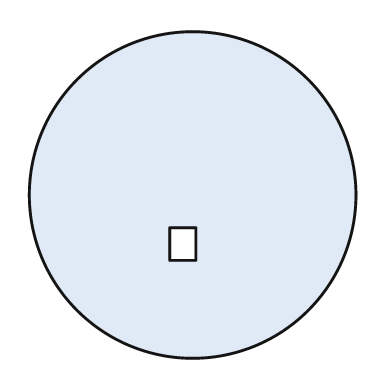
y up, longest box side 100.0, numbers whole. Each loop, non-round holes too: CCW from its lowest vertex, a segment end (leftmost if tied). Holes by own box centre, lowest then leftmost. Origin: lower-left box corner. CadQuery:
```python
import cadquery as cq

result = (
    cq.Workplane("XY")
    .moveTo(50.0, 50.0)
    .circle(50.0)
    .moveTo(43.0, 30.0)
    .lineTo(51.0, 30.0)
    .lineTo(51.0, 40.0)
    .lineTo(43.0, 40.0)
    .close()
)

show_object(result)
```